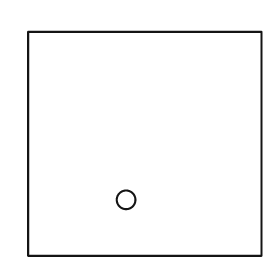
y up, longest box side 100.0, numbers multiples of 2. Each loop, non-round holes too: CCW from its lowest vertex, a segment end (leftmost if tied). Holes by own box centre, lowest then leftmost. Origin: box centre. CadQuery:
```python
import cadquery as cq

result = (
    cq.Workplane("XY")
    .moveTo(-50.0, -48.0)
    .lineTo(50.0, -48.0)
    .lineTo(50.0, 48.0)
    .lineTo(-50.0, 48.0)
    .close()
    .moveTo(-8.0, -24.0)
    .circle(4.0)
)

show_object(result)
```